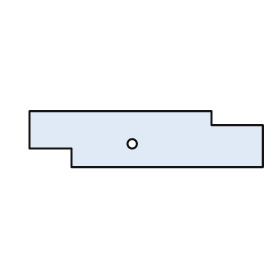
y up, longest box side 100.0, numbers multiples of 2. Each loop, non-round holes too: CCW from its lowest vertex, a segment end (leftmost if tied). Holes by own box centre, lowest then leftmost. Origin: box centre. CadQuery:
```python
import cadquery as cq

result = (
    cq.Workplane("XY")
    .moveTo(-32.0, -12.0)
    .lineTo(50.0, -12.0)
    .lineTo(50.0, 6.0)
    .lineTo(28.0, 6.0)
    .lineTo(28.0, 12.0)
    .lineTo(-50.0, 12.0)
    .lineTo(-50.0, -4.0)
    .lineTo(-32.0, -4.0)
    .close()
    .moveTo(-6.0, -2.0)
    .circle(2.0)
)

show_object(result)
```